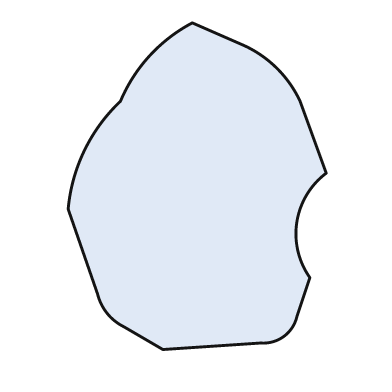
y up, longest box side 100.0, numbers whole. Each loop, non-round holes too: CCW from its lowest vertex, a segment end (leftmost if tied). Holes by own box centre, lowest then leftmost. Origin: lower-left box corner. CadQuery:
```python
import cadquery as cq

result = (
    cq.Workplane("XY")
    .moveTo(29.0, 0.0)
    .lineTo(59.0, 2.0)
    .threePointArc((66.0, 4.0), (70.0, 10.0))
    .lineTo(74.0, 22.0)
    .threePointArc((70.0, 39.0), (79.0, 54.0))
    .lineTo(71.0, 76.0)
    .threePointArc((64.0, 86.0), (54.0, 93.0))
    .lineTo(38.0, 100.0)
    .threePointArc((25.0, 90.0), (16.0, 76.0))
    .threePointArc((5.0, 61.0), (0.0, 43.0))
    .lineTo(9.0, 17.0)
    .threePointArc((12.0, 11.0), (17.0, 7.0))
    .close()
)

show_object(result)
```